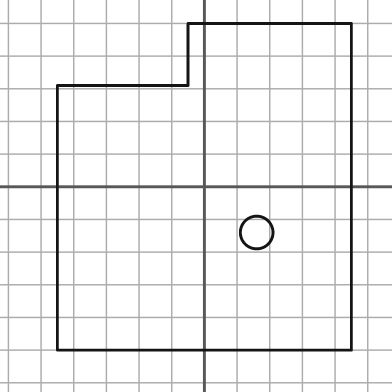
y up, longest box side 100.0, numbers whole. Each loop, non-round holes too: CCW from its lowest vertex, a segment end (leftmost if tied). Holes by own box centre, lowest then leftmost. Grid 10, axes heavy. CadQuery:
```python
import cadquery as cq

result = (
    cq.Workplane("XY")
    .moveTo(-45.0, -50.0)
    .lineTo(45.0, -50.0)
    .lineTo(45.0, 50.0)
    .lineTo(-5.0, 50.0)
    .lineTo(-5.0, 31.0)
    .lineTo(-45.0, 31.0)
    .close()
    .moveTo(16.0, -14.0)
    .circle(5.0)
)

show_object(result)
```